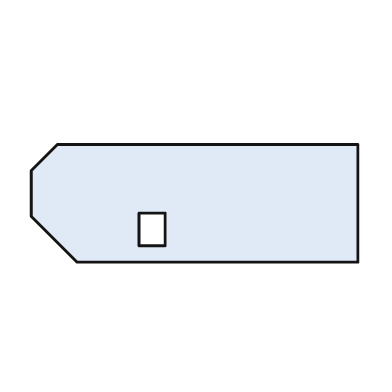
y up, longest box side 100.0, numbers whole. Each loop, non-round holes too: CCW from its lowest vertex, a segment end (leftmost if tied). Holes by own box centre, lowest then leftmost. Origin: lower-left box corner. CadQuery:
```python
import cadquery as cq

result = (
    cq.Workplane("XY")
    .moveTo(14.0, 0.0)
    .lineTo(100.0, 0.0)
    .lineTo(100.0, 36.0)
    .lineTo(8.0, 36.0)
    .lineTo(0.0, 28.0)
    .lineTo(0.0, 14.0)
    .close()
    .moveTo(33.0, 5.0)
    .lineTo(41.0, 5.0)
    .lineTo(41.0, 15.0)
    .lineTo(33.0, 15.0)
    .close()
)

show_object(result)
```